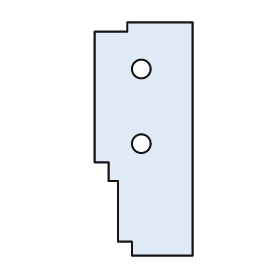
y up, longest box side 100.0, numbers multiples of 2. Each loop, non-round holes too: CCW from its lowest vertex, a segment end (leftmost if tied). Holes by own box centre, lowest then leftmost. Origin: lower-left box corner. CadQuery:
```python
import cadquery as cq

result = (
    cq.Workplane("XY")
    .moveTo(16.0, 0.0)
    .lineTo(42.0, 0.0)
    .lineTo(42.0, 100.0)
    .lineTo(14.0, 100.0)
    .lineTo(14.0, 96.0)
    .lineTo(0.0, 96.0)
    .lineTo(0.0, 40.0)
    .lineTo(6.0, 40.0)
    .lineTo(6.0, 32.0)
    .lineTo(10.0, 32.0)
    .lineTo(10.0, 6.0)
    .lineTo(16.0, 6.0)
    .close()
    .moveTo(20.0, 48.0)
    .circle(4.0)
    .moveTo(20.0, 80.0)
    .circle(4.0)
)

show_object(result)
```